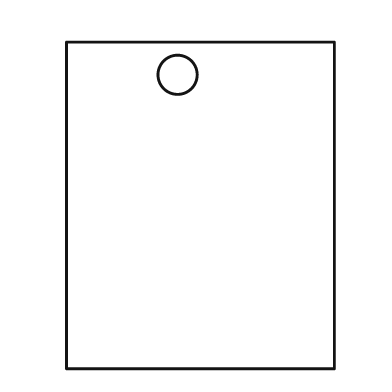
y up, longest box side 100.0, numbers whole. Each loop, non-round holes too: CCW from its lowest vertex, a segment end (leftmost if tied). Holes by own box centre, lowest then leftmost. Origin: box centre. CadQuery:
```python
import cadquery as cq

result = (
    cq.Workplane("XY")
    .moveTo(-41.0, -50.0)
    .lineTo(41.0, -50.0)
    .lineTo(41.0, 50.0)
    .lineTo(-41.0, 50.0)
    .close()
    .moveTo(-7.0, 40.0)
    .circle(6.0)
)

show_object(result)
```